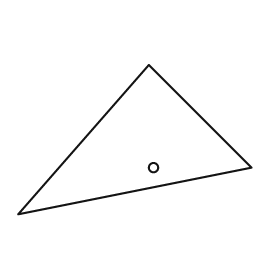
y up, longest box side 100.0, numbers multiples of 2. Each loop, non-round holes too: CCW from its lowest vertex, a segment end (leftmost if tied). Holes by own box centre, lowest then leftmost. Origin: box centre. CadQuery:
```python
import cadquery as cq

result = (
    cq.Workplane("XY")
    .moveTo(-50.0, -32.0)
    .lineTo(50.0, -12.0)
    .lineTo(6.0, 32.0)
    .close()
    .moveTo(8.0, -12.0)
    .circle(2.0)
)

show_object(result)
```